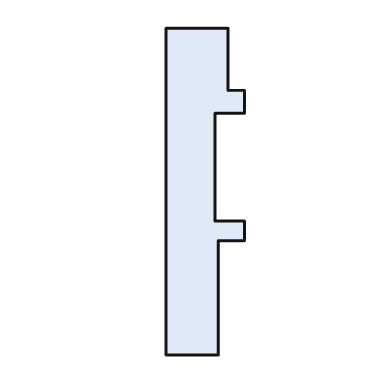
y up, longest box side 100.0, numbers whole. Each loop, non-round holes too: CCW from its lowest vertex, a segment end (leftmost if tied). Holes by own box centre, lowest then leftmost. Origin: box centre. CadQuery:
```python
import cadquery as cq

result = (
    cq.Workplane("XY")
    .moveTo(-12.0, -50.0)
    .lineTo(4.0, -50.0)
    .lineTo(4.0, -15.0)
    .lineTo(12.0, -15.0)
    .lineTo(12.0, -9.0)
    .lineTo(3.0, -9.0)
    .lineTo(3.0, 24.0)
    .lineTo(12.0, 24.0)
    .lineTo(12.0, 31.0)
    .lineTo(7.0, 31.0)
    .lineTo(7.0, 50.0)
    .lineTo(-12.0, 50.0)
    .close()
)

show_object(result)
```